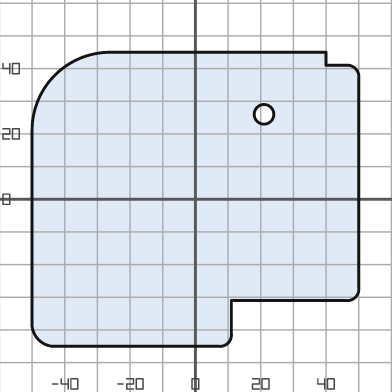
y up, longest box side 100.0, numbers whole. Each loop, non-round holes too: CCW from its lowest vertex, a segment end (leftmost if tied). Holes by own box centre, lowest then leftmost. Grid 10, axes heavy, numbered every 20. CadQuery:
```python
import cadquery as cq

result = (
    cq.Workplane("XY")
    .moveTo(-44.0, -45.0)
    .lineTo(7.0, -45.0)
    .threePointArc((10.0, -44.0), (11.0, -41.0))
    .lineTo(11.0, -31.0)
    .lineTo(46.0, -31.0)
    .threePointArc((49.0, -30.0), (50.0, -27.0))
    .lineTo(50.0, 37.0)
    .threePointArc((49.0, 40.0), (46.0, 41.0))
    .lineTo(40.0, 41.0)
    .lineTo(40.0, 45.0)
    .lineTo(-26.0, 45.0)
    .threePointArc((-43.0, 38.0), (-50.0, 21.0))
    .lineTo(-50.0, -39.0)
    .threePointArc((-48.0, -43.0), (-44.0, -45.0))
    .close()
    .moveTo(21.0, 26.0)
    .circle(3.0)
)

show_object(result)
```